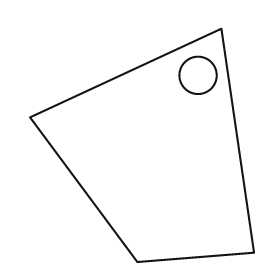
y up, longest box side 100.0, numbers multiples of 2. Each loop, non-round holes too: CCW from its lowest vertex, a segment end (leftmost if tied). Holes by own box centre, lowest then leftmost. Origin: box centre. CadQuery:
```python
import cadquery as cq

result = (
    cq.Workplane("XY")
    .moveTo(-2.0, -50.0)
    .lineTo(48.0, -46.0)
    .lineTo(34.0, 50.0)
    .lineTo(-48.0, 12.0)
    .close()
    .moveTo(24.0, 30.0)
    .circle(8.0)
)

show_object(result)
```